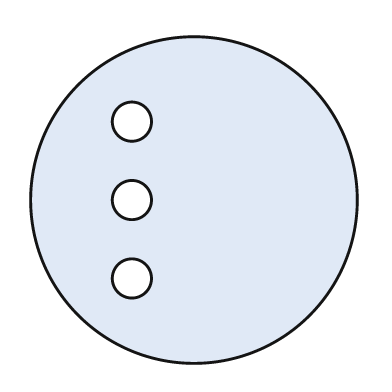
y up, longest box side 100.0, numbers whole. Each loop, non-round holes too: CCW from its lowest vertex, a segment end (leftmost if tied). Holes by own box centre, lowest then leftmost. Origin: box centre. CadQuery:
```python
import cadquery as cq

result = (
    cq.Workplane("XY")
    .moveTo(0.0, 0.0)
    .circle(50.0)
    .moveTo(-19.0, -24.0)
    .circle(6.0)
    .moveTo(-19.0, 0.0)
    .circle(6.0)
    .moveTo(-19.0, 24.0)
    .circle(6.0)
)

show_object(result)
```